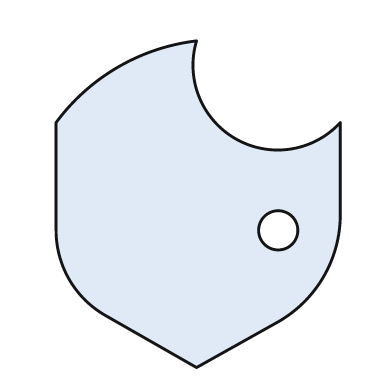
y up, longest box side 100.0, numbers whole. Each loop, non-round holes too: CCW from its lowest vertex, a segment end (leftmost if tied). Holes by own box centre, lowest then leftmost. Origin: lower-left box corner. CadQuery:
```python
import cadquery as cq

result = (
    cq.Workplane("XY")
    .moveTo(43.0, 0.0)
    .lineTo(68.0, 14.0)
    .threePointArc((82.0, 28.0), (87.0, 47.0))
    .lineTo(87.0, 75.0)
    .threePointArc((55.0, 70.0), (43.0, 100.0))
    .threePointArc((19.0, 92.0), (0.0, 75.0))
    .lineTo(0.0, 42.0)
    .threePointArc((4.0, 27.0), (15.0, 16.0))
    .close()
    .moveTo(68.0, 42.0)
    .circle(6.0)
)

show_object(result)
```